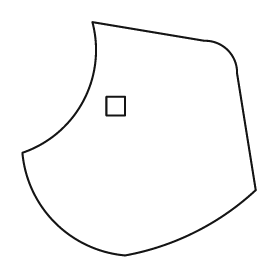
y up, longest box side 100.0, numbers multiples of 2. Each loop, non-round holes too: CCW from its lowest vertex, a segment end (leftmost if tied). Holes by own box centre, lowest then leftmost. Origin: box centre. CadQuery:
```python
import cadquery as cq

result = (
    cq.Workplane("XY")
    .moveTo(-6.0, -50.0)
    .threePointArc((24.0, -40.0), (50.0, -22.0))
    .lineTo(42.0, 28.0)
    .threePointArc((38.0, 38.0), (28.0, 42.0))
    .lineTo(-20.0, 50.0)
    .threePointArc((-24.0, 16.0), (-50.0, -6.0))
    .threePointArc((-36.0, -36.0), (-6.0, -50.0))
    .close()
    .moveTo(-14.0, 10.0)
    .lineTo(-6.0, 10.0)
    .lineTo(-6.0, 18.0)
    .lineTo(-14.0, 18.0)
    .close()
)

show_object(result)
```